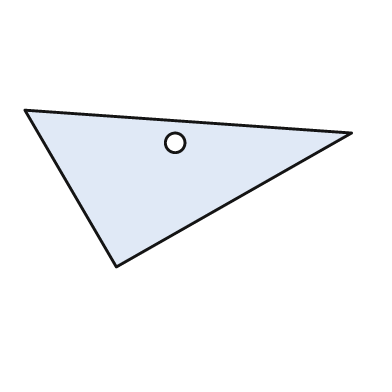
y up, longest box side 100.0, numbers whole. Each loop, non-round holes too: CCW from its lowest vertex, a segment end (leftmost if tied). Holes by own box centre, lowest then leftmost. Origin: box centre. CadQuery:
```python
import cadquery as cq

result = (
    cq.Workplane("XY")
    .moveTo(-22.0, -24.0)
    .lineTo(50.0, 17.0)
    .lineTo(-50.0, 24.0)
    .close()
    .moveTo(-4.0, 14.0)
    .circle(3.0)
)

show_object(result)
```